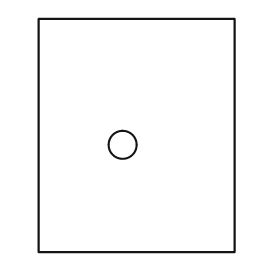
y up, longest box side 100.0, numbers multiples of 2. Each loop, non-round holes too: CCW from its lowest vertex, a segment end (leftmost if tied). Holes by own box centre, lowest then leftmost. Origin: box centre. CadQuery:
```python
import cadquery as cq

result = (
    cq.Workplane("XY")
    .moveTo(-42.0, -50.0)
    .lineTo(42.0, -50.0)
    .lineTo(42.0, 50.0)
    .lineTo(-42.0, 50.0)
    .close()
    .moveTo(-6.0, -4.0)
    .circle(6.0)
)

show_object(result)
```